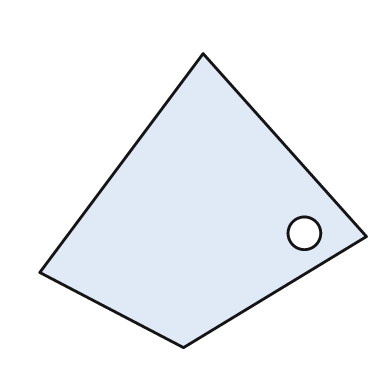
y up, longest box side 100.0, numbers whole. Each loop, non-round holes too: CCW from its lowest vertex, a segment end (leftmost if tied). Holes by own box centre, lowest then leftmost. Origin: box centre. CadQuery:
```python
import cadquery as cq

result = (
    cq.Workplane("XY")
    .moveTo(-6.0, -45.0)
    .lineTo(50.0, -11.0)
    .lineTo(0.0, 45.0)
    .lineTo(-50.0, -22.0)
    .close()
    .moveTo(31.0, -10.0)
    .circle(5.0)
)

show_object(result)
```